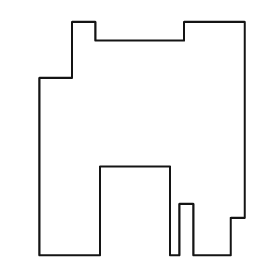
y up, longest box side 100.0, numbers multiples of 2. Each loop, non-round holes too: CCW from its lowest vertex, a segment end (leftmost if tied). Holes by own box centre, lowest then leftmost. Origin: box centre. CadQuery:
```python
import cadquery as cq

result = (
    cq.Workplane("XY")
    .moveTo(-44.0, -50.0)
    .lineTo(-18.0, -50.0)
    .lineTo(-18.0, -12.0)
    .lineTo(12.0, -12.0)
    .lineTo(12.0, -50.0)
    .lineTo(16.0, -50.0)
    .lineTo(16.0, -28.0)
    .lineTo(22.0, -28.0)
    .lineTo(22.0, -50.0)
    .lineTo(38.0, -50.0)
    .lineTo(38.0, -34.0)
    .lineTo(44.0, -34.0)
    .lineTo(44.0, 50.0)
    .lineTo(18.0, 50.0)
    .lineTo(18.0, 42.0)
    .lineTo(-20.0, 42.0)
    .lineTo(-20.0, 50.0)
    .lineTo(-30.0, 50.0)
    .lineTo(-30.0, 26.0)
    .lineTo(-44.0, 26.0)
    .close()
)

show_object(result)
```